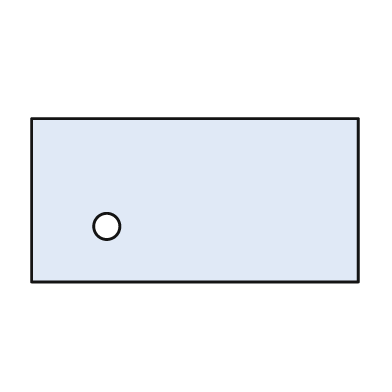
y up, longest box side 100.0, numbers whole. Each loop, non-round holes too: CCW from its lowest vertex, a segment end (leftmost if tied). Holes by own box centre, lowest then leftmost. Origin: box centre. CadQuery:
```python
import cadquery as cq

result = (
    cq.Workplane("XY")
    .moveTo(-50.0, -25.0)
    .lineTo(50.0, -25.0)
    .lineTo(50.0, 25.0)
    .lineTo(-50.0, 25.0)
    .close()
    .moveTo(-27.0, -8.0)
    .circle(4.0)
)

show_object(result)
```